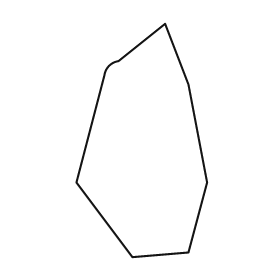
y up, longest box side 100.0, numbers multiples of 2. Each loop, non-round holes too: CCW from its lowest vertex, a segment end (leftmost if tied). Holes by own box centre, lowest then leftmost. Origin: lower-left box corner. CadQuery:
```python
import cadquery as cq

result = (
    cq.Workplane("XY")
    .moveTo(24.0, 0.0)
    .lineTo(48.0, 2.0)
    .lineTo(56.0, 32.0)
    .lineTo(48.0, 74.0)
    .lineTo(38.0, 100.0)
    .lineTo(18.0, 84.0)
    .threePointArc((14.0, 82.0), (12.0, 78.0))
    .lineTo(0.0, 32.0)
    .close()
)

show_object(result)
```